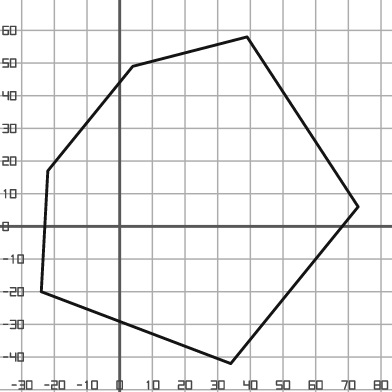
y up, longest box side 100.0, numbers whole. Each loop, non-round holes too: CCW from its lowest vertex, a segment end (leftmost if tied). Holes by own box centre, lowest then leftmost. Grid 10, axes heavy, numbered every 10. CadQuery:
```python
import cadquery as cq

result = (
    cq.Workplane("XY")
    .moveTo(34.0, -42.0)
    .lineTo(73.0, 6.0)
    .lineTo(39.0, 58.0)
    .lineTo(4.0, 49.0)
    .lineTo(-22.0, 17.0)
    .lineTo(-24.0, -20.0)
    .close()
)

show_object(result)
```